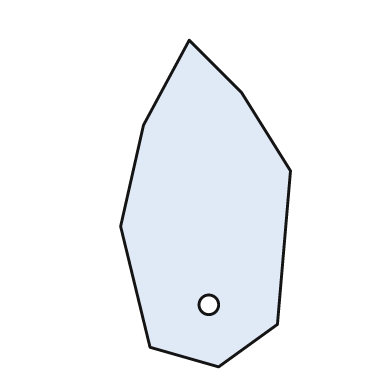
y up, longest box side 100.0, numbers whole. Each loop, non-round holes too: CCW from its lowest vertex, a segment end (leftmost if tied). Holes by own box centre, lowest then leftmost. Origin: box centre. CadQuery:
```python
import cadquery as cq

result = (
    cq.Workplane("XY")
    .moveTo(4.0, -50.0)
    .lineTo(22.0, -37.0)
    .lineTo(26.0, 10.0)
    .lineTo(11.0, 34.0)
    .lineTo(-5.0, 50.0)
    .lineTo(-19.0, 24.0)
    .lineTo(-26.0, -7.0)
    .lineTo(-17.0, -44.0)
    .close()
    .moveTo(1.0, -31.0)
    .circle(3.0)
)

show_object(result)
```